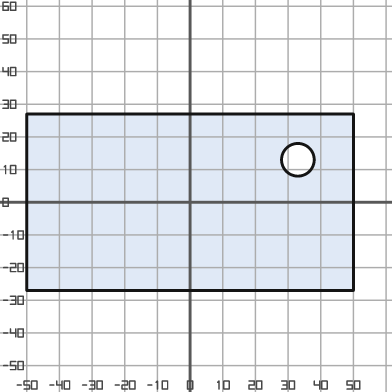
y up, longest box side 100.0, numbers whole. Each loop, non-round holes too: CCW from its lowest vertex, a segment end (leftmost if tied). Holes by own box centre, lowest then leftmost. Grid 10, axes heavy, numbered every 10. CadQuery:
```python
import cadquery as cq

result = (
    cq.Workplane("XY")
    .moveTo(-50.0, -27.0)
    .lineTo(50.0, -27.0)
    .lineTo(50.0, 27.0)
    .lineTo(-50.0, 27.0)
    .close()
    .moveTo(33.0, 13.0)
    .circle(5.0)
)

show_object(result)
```